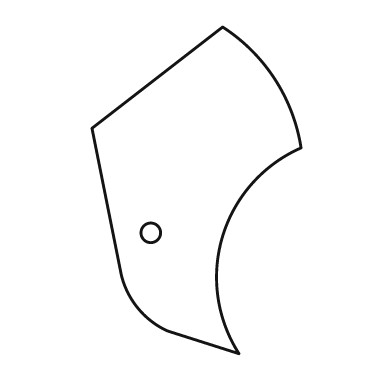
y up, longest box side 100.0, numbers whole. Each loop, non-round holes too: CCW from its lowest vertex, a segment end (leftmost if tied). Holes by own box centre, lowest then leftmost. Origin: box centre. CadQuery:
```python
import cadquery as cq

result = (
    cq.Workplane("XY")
    .moveTo(13.0, -50.0)
    .threePointArc((8.0, -14.0), (32.0, 13.0))
    .threePointArc((24.0, 34.0), (8.0, 50.0))
    .lineTo(-32.0, 19.0)
    .lineTo(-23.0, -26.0)
    .threePointArc((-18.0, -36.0), (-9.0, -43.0))
    .close()
    .moveTo(-14.0, -13.0)
    .circle(3.0)
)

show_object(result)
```